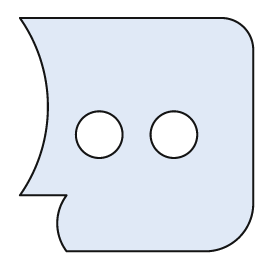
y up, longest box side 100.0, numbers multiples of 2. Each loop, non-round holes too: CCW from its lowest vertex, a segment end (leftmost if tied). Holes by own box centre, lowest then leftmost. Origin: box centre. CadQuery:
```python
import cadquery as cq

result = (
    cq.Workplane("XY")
    .moveTo(-30.0, -50.0)
    .lineTo(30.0, -50.0)
    .threePointArc((44.0, -44.0), (50.0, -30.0))
    .lineTo(50.0, 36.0)
    .threePointArc((46.0, 46.0), (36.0, 50.0))
    .lineTo(-50.0, 50.0)
    .threePointArc((-38.0, 12.0), (-50.0, -26.0))
    .lineTo(-30.0, -26.0)
    .threePointArc((-34.0, -38.0), (-30.0, -50.0))
    .close()
    .moveTo(-16.0, 0.0)
    .circle(10.0)
    .moveTo(16.0, 0.0)
    .circle(10.0)
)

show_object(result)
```